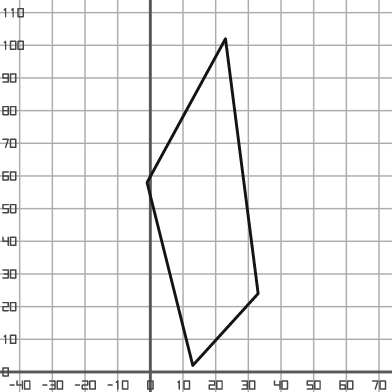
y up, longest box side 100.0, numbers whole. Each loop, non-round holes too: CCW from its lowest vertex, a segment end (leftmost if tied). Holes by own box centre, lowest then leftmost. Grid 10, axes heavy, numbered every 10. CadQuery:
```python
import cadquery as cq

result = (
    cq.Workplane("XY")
    .moveTo(13.0, 2.0)
    .lineTo(33.0, 24.0)
    .lineTo(23.0, 102.0)
    .lineTo(-1.0, 58.0)
    .close()
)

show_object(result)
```